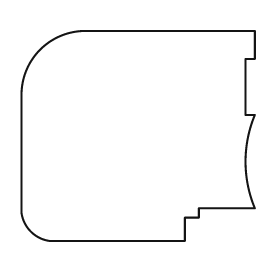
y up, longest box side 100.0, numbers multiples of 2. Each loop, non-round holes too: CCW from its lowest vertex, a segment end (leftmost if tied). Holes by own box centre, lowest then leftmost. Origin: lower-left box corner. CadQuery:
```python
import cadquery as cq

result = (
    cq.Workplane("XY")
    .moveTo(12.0, 0.0)
    .lineTo(70.0, 0.0)
    .lineTo(70.0, 10.0)
    .lineTo(76.0, 10.0)
    .lineTo(76.0, 14.0)
    .lineTo(100.0, 14.0)
    .threePointArc((96.0, 34.0), (100.0, 54.0))
    .lineTo(96.0, 54.0)
    .lineTo(96.0, 78.0)
    .lineTo(100.0, 78.0)
    .lineTo(100.0, 90.0)
    .lineTo(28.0, 90.0)
    .threePointArc((8.0, 82.0), (0.0, 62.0))
    .lineTo(0.0, 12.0)
    .threePointArc((4.0, 4.0), (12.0, 0.0))
    .close()
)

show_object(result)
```